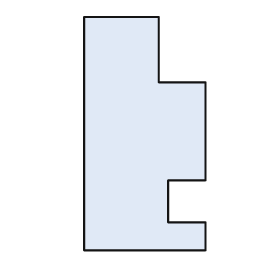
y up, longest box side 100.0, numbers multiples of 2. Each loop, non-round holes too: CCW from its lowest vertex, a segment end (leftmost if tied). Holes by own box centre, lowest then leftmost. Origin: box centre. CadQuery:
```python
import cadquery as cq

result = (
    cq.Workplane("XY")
    .moveTo(-26.0, -50.0)
    .lineTo(26.0, -50.0)
    .lineTo(26.0, -38.0)
    .lineTo(10.0, -38.0)
    .lineTo(10.0, -20.0)
    .lineTo(26.0, -20.0)
    .lineTo(26.0, 22.0)
    .lineTo(6.0, 22.0)
    .lineTo(6.0, 50.0)
    .lineTo(-26.0, 50.0)
    .close()
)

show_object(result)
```